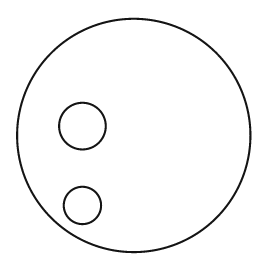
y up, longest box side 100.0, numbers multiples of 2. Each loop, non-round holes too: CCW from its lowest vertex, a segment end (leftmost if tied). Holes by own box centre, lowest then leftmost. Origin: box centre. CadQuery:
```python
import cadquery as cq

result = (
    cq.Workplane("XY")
    .moveTo(0.0, 0.0)
    .circle(50.0)
    .moveTo(-22.0, -30.0)
    .circle(8.0)
    .moveTo(-22.0, 4.0)
    .circle(10.0)
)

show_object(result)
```